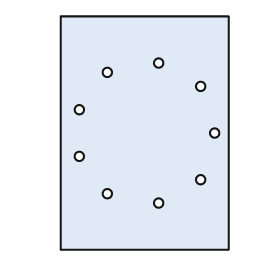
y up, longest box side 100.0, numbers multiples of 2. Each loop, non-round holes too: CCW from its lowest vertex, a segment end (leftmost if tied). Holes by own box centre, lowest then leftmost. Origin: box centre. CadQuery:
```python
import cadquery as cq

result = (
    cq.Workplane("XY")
    .moveTo(-36.0, -50.0)
    .lineTo(36.0, -50.0)
    .lineTo(36.0, 50.0)
    .lineTo(-36.0, 50.0)
    .close()
    .moveTo(6.0, -30.0)
    .circle(2.0)
    .moveTo(-16.0, -26.0)
    .circle(2.0)
    .moveTo(24.0, -20.0)
    .circle(2.0)
    .moveTo(-28.0, -10.0)
    .circle(2.0)
    .moveTo(30.0, 0.0)
    .circle(2.0)
    .moveTo(-28.0, 10.0)
    .circle(2.0)
    .moveTo(24.0, 20.0)
    .circle(2.0)
    .moveTo(-16.0, 26.0)
    .circle(2.0)
    .moveTo(6.0, 30.0)
    .circle(2.0)
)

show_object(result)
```